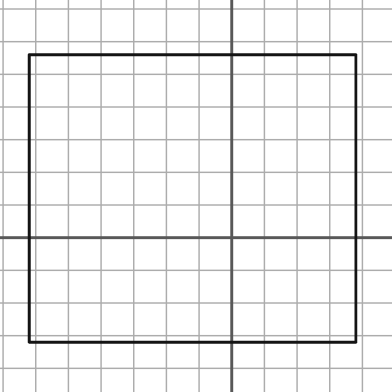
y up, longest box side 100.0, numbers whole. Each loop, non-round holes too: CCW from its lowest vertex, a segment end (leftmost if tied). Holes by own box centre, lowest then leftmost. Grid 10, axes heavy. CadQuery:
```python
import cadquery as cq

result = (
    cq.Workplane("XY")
    .moveTo(-62.0, -32.0)
    .lineTo(38.0, -32.0)
    .lineTo(38.0, 56.0)
    .lineTo(-62.0, 56.0)
    .close()
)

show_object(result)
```